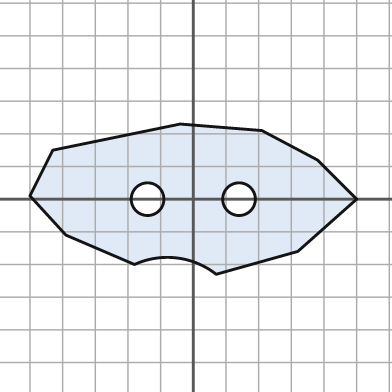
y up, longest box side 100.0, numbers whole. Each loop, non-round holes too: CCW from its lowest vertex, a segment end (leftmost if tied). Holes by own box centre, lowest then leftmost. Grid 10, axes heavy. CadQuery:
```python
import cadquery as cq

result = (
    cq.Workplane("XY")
    .moveTo(7.0, -23.0)
    .lineTo(32.0, -16.0)
    .lineTo(50.0, 0.0)
    .lineTo(38.0, 12.0)
    .lineTo(21.0, 21.0)
    .lineTo(-4.0, 23.0)
    .lineTo(-43.0, 15.0)
    .lineTo(-50.0, 1.0)
    .lineTo(-39.0, -11.0)
    .lineTo(-18.0, -20.0)
    .threePointArc((-5.0, -18.0), (7.0, -23.0))
    .close()
    .moveTo(-14.0, 0.0)
    .circle(5.0)
    .moveTo(14.0, 0.0)
    .circle(5.0)
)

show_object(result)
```